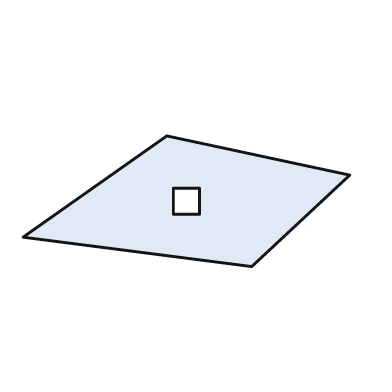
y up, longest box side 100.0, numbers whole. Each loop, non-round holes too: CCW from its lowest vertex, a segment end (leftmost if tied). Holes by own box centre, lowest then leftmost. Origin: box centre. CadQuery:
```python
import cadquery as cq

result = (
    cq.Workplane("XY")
    .moveTo(20.0, -20.0)
    .lineTo(50.0, 8.0)
    .lineTo(-6.0, 20.0)
    .lineTo(-50.0, -11.0)
    .close()
    .moveTo(-4.0, -4.0)
    .lineTo(4.0, -4.0)
    .lineTo(4.0, 4.0)
    .lineTo(-4.0, 4.0)
    .close()
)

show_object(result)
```